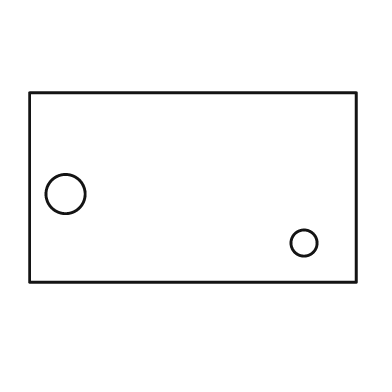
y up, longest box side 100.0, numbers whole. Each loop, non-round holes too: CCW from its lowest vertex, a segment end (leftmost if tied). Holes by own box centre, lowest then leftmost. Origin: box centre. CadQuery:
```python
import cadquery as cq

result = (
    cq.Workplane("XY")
    .moveTo(-50.0, -29.0)
    .lineTo(50.0, -29.0)
    .lineTo(50.0, 29.0)
    .lineTo(-50.0, 29.0)
    .close()
    .moveTo(34.0, -17.0)
    .circle(4.0)
    .moveTo(-39.0, -2.0)
    .circle(6.0)
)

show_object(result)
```